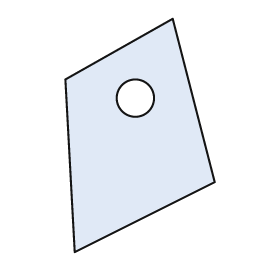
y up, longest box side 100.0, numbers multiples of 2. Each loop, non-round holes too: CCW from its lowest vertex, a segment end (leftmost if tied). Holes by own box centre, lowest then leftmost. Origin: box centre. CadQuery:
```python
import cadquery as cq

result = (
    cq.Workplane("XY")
    .moveTo(-28.0, -50.0)
    .lineTo(32.0, -20.0)
    .lineTo(14.0, 50.0)
    .lineTo(-32.0, 24.0)
    .close()
    .moveTo(-2.0, 16.0)
    .circle(8.0)
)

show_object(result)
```